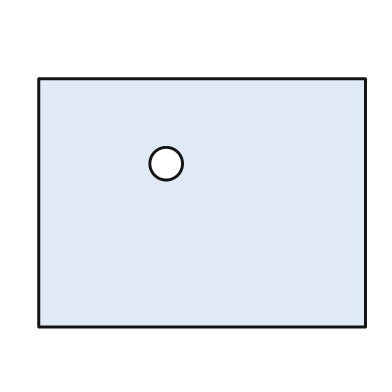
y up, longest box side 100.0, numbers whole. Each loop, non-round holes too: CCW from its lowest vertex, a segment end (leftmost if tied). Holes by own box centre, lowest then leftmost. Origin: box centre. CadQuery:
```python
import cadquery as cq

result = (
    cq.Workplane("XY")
    .moveTo(-50.0, -38.0)
    .lineTo(50.0, -38.0)
    .lineTo(50.0, 38.0)
    .lineTo(-50.0, 38.0)
    .close()
    .moveTo(-11.0, 12.0)
    .circle(5.0)
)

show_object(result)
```